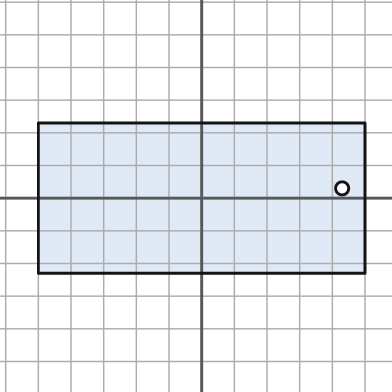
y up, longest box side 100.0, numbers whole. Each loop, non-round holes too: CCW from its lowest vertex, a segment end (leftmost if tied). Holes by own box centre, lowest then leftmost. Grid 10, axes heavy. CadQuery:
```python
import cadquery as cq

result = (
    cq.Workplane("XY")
    .moveTo(-50.0, -23.0)
    .lineTo(50.0, -23.0)
    .lineTo(50.0, 23.0)
    .lineTo(-50.0, 23.0)
    .close()
    .moveTo(43.0, 3.0)
    .circle(2.0)
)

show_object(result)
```